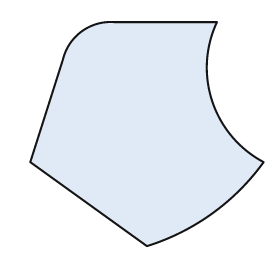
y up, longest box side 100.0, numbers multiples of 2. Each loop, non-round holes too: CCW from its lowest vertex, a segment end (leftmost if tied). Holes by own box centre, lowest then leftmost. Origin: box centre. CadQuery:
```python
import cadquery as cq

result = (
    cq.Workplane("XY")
    .moveTo(0.0, -48.0)
    .threePointArc((28.0, -34.0), (50.0, -12.0))
    .threePointArc((28.0, 14.0), (30.0, 48.0))
    .lineTo(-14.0, 48.0)
    .threePointArc((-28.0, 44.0), (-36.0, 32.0))
    .lineTo(-50.0, -12.0)
    .close()
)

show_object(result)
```